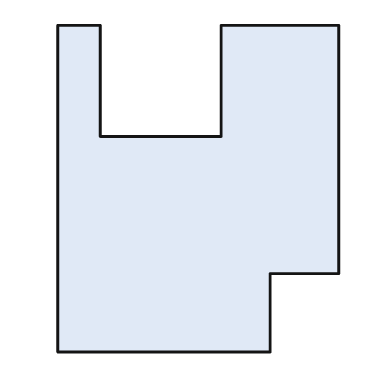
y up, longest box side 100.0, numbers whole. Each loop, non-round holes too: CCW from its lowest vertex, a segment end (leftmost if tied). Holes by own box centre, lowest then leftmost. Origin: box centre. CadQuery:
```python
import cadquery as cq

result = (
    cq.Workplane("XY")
    .moveTo(-43.0, -50.0)
    .lineTo(22.0, -50.0)
    .lineTo(22.0, -26.0)
    .lineTo(43.0, -26.0)
    .lineTo(43.0, 50.0)
    .lineTo(7.0, 50.0)
    .lineTo(7.0, 16.0)
    .lineTo(-30.0, 16.0)
    .lineTo(-30.0, 50.0)
    .lineTo(-43.0, 50.0)
    .close()
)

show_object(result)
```